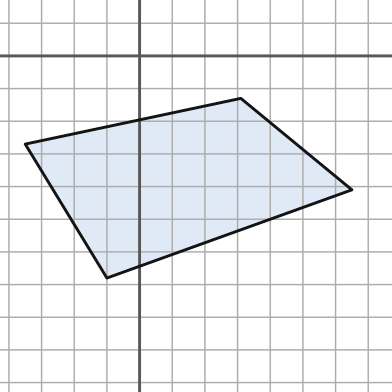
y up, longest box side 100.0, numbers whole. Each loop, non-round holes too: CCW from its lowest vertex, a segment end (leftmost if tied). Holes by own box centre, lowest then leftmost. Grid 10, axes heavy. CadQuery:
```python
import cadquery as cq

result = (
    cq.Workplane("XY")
    .moveTo(-10.0, -68.0)
    .lineTo(65.0, -41.0)
    .lineTo(31.0, -13.0)
    .lineTo(-35.0, -27.0)
    .close()
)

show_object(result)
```